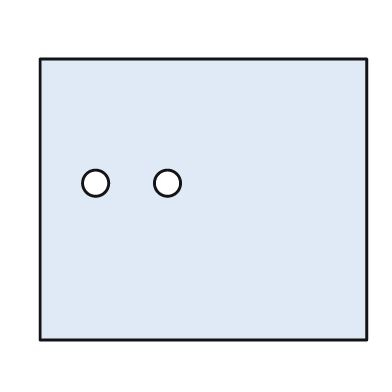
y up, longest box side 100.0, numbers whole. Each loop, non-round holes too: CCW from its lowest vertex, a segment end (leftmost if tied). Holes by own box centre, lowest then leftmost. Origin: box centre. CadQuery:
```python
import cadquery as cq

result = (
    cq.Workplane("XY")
    .moveTo(-50.0, -43.0)
    .lineTo(50.0, -43.0)
    .lineTo(50.0, 43.0)
    .lineTo(-50.0, 43.0)
    .close()
    .moveTo(-33.0, 5.0)
    .circle(4.0)
    .moveTo(-11.0, 5.0)
    .circle(4.0)
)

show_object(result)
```